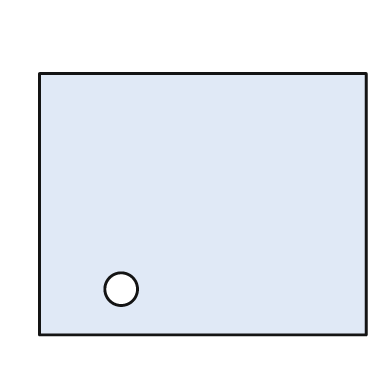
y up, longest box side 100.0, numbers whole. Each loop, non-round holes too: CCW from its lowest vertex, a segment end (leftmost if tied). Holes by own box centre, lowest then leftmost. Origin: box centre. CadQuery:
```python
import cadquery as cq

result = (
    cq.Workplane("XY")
    .moveTo(-50.0, -40.0)
    .lineTo(50.0, -40.0)
    .lineTo(50.0, 40.0)
    .lineTo(-50.0, 40.0)
    .close()
    .moveTo(-25.0, -26.0)
    .circle(5.0)
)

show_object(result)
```